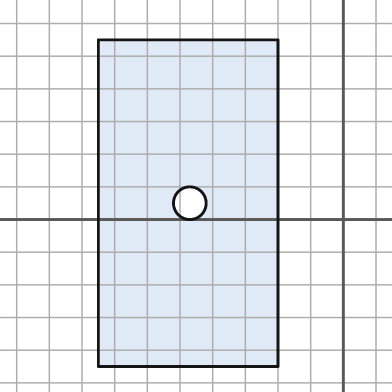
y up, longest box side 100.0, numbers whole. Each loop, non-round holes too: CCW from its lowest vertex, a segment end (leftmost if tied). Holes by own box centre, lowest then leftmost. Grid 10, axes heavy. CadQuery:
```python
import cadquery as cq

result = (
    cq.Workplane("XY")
    .moveTo(-75.0, -45.0)
    .lineTo(-20.0, -45.0)
    .lineTo(-20.0, 55.0)
    .lineTo(-75.0, 55.0)
    .close()
    .moveTo(-47.0, 5.0)
    .circle(5.0)
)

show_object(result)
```